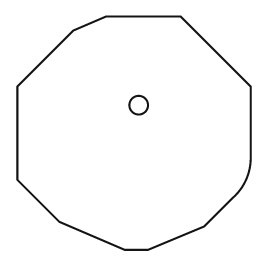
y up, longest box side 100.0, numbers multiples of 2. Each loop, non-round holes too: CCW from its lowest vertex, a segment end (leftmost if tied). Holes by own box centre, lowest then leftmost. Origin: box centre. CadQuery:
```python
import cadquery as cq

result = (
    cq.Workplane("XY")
    .moveTo(-4.0, -50.0)
    .lineTo(6.0, -50.0)
    .lineTo(30.0, -40.0)
    .lineTo(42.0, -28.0)
    .threePointArc((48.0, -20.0), (50.0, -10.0))
    .lineTo(50.0, 20.0)
    .lineTo(20.0, 50.0)
    .lineTo(-12.0, 50.0)
    .lineTo(-26.0, 44.0)
    .lineTo(-50.0, 20.0)
    .lineTo(-50.0, -20.0)
    .lineTo(-32.0, -38.0)
    .close()
    .moveTo(2.0, 12.0)
    .circle(4.0)
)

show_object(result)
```